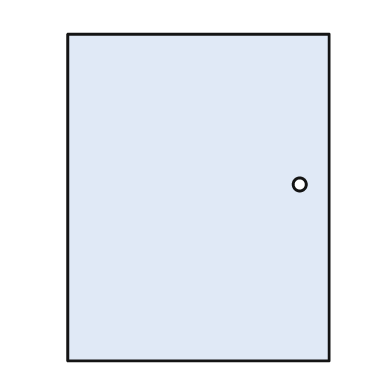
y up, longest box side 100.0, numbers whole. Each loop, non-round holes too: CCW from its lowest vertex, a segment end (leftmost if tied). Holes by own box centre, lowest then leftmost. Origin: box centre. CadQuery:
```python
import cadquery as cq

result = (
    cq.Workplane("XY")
    .moveTo(-40.0, -50.0)
    .lineTo(40.0, -50.0)
    .lineTo(40.0, 50.0)
    .lineTo(-40.0, 50.0)
    .close()
    .moveTo(31.0, 4.0)
    .circle(2.0)
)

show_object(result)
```